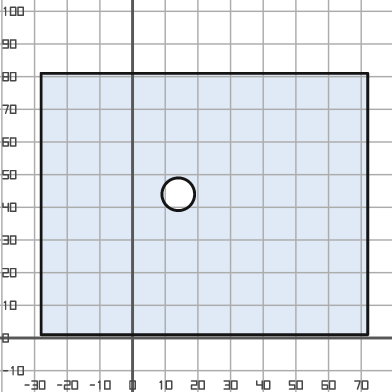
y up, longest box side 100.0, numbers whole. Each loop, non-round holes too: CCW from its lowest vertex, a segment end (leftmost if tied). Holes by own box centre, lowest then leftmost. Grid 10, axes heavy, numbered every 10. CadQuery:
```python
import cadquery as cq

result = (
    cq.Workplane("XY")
    .moveTo(-28.0, 1.0)
    .lineTo(72.0, 1.0)
    .lineTo(72.0, 81.0)
    .lineTo(-28.0, 81.0)
    .close()
    .moveTo(14.0, 44.0)
    .circle(5.0)
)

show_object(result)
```